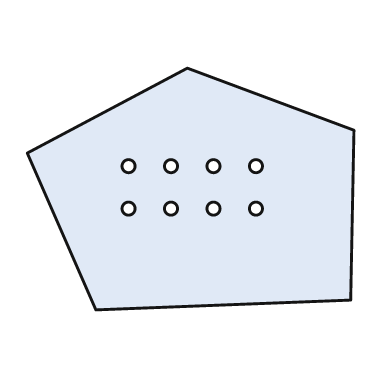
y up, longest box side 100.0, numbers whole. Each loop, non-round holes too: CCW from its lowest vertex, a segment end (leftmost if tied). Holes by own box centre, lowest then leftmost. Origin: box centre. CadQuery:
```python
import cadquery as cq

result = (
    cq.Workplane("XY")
    .moveTo(-29.0, -37.0)
    .lineTo(49.0, -34.0)
    .lineTo(50.0, 18.0)
    .lineTo(-1.0, 37.0)
    .lineTo(-50.0, 11.0)
    .close()
    .moveTo(-19.0, -6.0)
    .circle(2.0)
    .moveTo(-6.0, -6.0)
    .circle(2.0)
    .moveTo(7.0, -6.0)
    .circle(2.0)
    .moveTo(20.0, -6.0)
    .circle(2.0)
    .moveTo(-19.0, 7.0)
    .circle(2.0)
    .moveTo(-6.0, 7.0)
    .circle(2.0)
    .moveTo(7.0, 7.0)
    .circle(2.0)
    .moveTo(20.0, 7.0)
    .circle(2.0)
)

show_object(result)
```